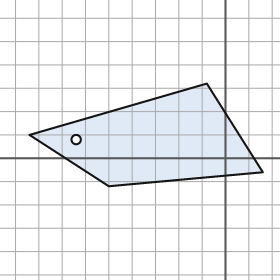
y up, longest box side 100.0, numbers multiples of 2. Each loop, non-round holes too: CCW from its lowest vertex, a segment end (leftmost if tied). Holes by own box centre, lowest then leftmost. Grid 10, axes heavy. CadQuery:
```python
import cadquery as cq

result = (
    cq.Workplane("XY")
    .moveTo(-50.0, -12.0)
    .lineTo(16.0, -6.0)
    .lineTo(-8.0, 32.0)
    .lineTo(-84.0, 10.0)
    .close()
    .moveTo(-64.0, 8.0)
    .circle(2.0)
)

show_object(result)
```